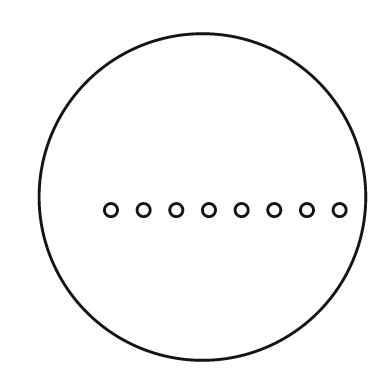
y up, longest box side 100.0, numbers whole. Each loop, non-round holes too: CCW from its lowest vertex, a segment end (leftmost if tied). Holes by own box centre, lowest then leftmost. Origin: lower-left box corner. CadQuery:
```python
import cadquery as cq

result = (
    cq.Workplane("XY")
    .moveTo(50.0, 50.0)
    .circle(50.0)
    .moveTo(22.0, 46.0)
    .circle(2.0)
    .moveTo(32.0, 46.0)
    .circle(2.0)
    .moveTo(42.0, 46.0)
    .circle(2.0)
    .moveTo(52.0, 46.0)
    .circle(2.0)
    .moveTo(62.0, 46.0)
    .circle(2.0)
    .moveTo(72.0, 46.0)
    .circle(2.0)
    .moveTo(82.0, 46.0)
    .circle(2.0)
    .moveTo(92.0, 46.0)
    .circle(2.0)
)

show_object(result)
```